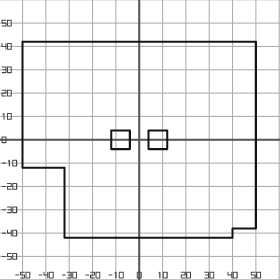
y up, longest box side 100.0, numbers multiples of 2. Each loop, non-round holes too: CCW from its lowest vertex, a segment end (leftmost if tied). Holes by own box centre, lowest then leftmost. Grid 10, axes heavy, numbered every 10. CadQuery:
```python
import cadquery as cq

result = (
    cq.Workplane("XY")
    .moveTo(-32.0, -42.0)
    .lineTo(40.0, -42.0)
    .lineTo(40.0, -38.0)
    .lineTo(50.0, -38.0)
    .lineTo(50.0, 42.0)
    .lineTo(-50.0, 42.0)
    .lineTo(-50.0, -12.0)
    .lineTo(-32.0, -12.0)
    .close()
    .moveTo(-12.0, -4.0)
    .lineTo(-4.0, -4.0)
    .lineTo(-4.0, 4.0)
    .lineTo(-12.0, 4.0)
    .close()
    .moveTo(4.0, -4.0)
    .lineTo(12.0, -4.0)
    .lineTo(12.0, 4.0)
    .lineTo(4.0, 4.0)
    .close()
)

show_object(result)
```